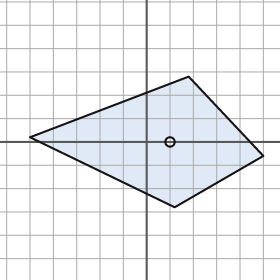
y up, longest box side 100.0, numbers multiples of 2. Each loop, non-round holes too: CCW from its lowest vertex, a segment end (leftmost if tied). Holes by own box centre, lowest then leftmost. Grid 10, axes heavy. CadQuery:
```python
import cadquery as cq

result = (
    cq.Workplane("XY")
    .moveTo(12.0, -28.0)
    .lineTo(50.0, -6.0)
    .lineTo(18.0, 28.0)
    .lineTo(-50.0, 2.0)
    .close()
    .moveTo(10.0, 0.0)
    .circle(2.0)
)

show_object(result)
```